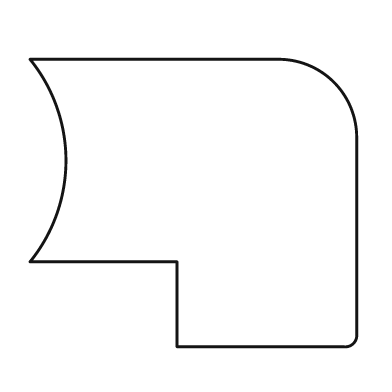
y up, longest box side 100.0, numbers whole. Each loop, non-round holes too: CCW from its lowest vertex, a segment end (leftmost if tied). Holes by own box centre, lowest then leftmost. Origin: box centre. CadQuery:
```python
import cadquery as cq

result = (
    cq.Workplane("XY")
    .moveTo(-5.0, -44.0)
    .lineTo(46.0, -44.0)
    .threePointArc((49.0, -43.0), (50.0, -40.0))
    .lineTo(50.0, 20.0)
    .threePointArc((43.0, 37.0), (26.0, 44.0))
    .lineTo(-50.0, 44.0)
    .threePointArc((-39.0, 13.0), (-50.0, -18.0))
    .lineTo(-5.0, -18.0)
    .close()
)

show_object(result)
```